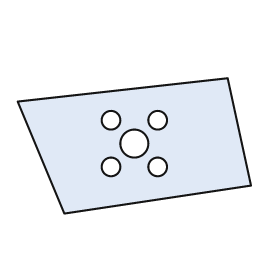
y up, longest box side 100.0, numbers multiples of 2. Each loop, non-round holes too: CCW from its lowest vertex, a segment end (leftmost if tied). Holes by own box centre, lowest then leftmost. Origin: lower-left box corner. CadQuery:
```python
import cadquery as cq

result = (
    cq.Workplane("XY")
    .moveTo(20.0, 0.0)
    .lineTo(100.0, 12.0)
    .lineTo(90.0, 58.0)
    .lineTo(0.0, 48.0)
    .close()
    .moveTo(40.0, 20.0)
    .circle(4.0)
    .moveTo(60.0, 20.0)
    .circle(4.0)
    .moveTo(50.0, 30.0)
    .circle(6.0)
    .moveTo(40.0, 40.0)
    .circle(4.0)
    .moveTo(60.0, 40.0)
    .circle(4.0)
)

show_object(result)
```